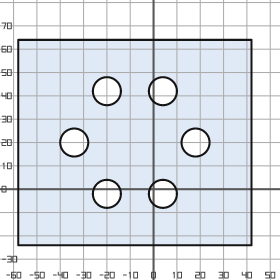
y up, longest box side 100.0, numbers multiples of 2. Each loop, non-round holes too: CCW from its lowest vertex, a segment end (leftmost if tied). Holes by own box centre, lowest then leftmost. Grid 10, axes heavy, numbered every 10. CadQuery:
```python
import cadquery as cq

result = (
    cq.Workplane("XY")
    .moveTo(-58.0, -24.0)
    .lineTo(42.0, -24.0)
    .lineTo(42.0, 64.0)
    .lineTo(-58.0, 64.0)
    .close()
    .moveTo(-20.0, -2.0)
    .circle(6.0)
    .moveTo(4.0, -2.0)
    .circle(6.0)
    .moveTo(-34.0, 20.0)
    .circle(6.0)
    .moveTo(18.0, 20.0)
    .circle(6.0)
    .moveTo(-20.0, 42.0)
    .circle(6.0)
    .moveTo(4.0, 42.0)
    .circle(6.0)
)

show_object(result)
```